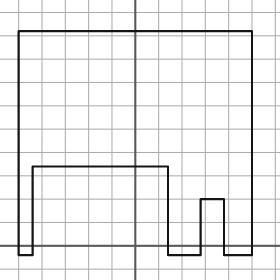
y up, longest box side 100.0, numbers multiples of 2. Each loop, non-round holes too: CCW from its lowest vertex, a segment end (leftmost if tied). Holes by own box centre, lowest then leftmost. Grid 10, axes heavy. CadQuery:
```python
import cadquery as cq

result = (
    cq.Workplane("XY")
    .moveTo(-50.0, -4.0)
    .lineTo(-44.0, -4.0)
    .lineTo(-44.0, 34.0)
    .lineTo(14.0, 34.0)
    .lineTo(14.0, -4.0)
    .lineTo(28.0, -4.0)
    .lineTo(28.0, 20.0)
    .lineTo(38.0, 20.0)
    .lineTo(38.0, -4.0)
    .lineTo(50.0, -4.0)
    .lineTo(50.0, 92.0)
    .lineTo(-50.0, 92.0)
    .close()
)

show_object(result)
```